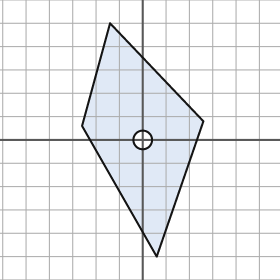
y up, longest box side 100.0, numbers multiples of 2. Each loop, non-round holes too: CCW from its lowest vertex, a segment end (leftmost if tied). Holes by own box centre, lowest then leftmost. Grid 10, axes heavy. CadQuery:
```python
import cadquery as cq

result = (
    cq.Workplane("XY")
    .moveTo(6.0, -50.0)
    .lineTo(26.0, 8.0)
    .lineTo(-14.0, 50.0)
    .lineTo(-26.0, 6.0)
    .close()
    .moveTo(0.0, 0.0)
    .circle(4.0)
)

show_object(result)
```